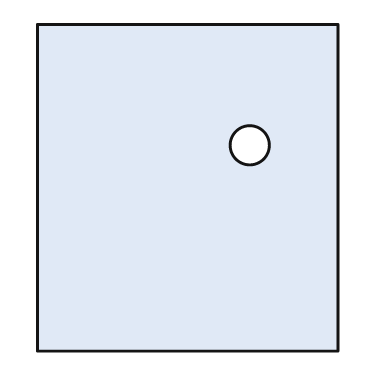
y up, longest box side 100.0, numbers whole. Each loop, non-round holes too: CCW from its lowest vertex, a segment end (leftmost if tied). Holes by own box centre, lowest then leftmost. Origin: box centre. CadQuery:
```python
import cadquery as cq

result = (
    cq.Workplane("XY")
    .moveTo(-46.0, -50.0)
    .lineTo(46.0, -50.0)
    .lineTo(46.0, 50.0)
    .lineTo(-46.0, 50.0)
    .close()
    .moveTo(19.0, 13.0)
    .circle(6.0)
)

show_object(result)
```